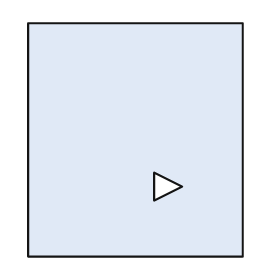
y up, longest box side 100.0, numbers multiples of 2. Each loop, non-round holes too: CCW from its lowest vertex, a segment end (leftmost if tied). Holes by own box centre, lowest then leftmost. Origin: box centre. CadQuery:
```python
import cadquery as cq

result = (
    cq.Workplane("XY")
    .moveTo(-46.0, -50.0)
    .lineTo(46.0, -50.0)
    .lineTo(46.0, 50.0)
    .lineTo(-46.0, 50.0)
    .close()
    .moveTo(8.0, -26.0)
    .lineTo(20.0, -20.0)
    .lineTo(8.0, -14.0)
    .close()
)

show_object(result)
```